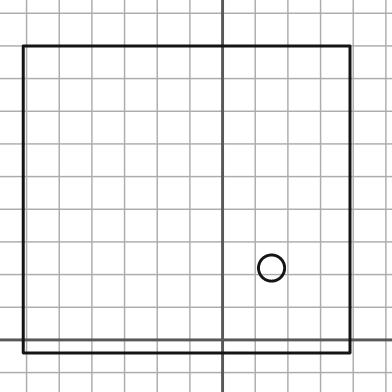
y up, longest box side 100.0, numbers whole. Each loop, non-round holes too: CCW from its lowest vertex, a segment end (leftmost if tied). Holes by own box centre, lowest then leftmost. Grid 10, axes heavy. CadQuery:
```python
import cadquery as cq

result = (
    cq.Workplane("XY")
    .moveTo(-61.0, -4.0)
    .lineTo(39.0, -4.0)
    .lineTo(39.0, 90.0)
    .lineTo(-61.0, 90.0)
    .close()
    .moveTo(15.0, 22.0)
    .circle(4.0)
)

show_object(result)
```